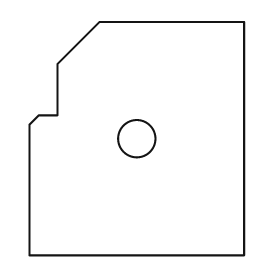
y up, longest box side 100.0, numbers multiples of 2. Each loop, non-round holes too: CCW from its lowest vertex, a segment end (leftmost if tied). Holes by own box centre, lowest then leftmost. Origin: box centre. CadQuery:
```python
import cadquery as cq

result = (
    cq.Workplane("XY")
    .moveTo(-46.0, -50.0)
    .lineTo(46.0, -50.0)
    .lineTo(46.0, 50.0)
    .lineTo(-16.0, 50.0)
    .lineTo(-34.0, 32.0)
    .lineTo(-34.0, 10.0)
    .lineTo(-42.0, 10.0)
    .lineTo(-46.0, 6.0)
    .close()
    .moveTo(0.0, 0.0)
    .circle(8.0)
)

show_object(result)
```